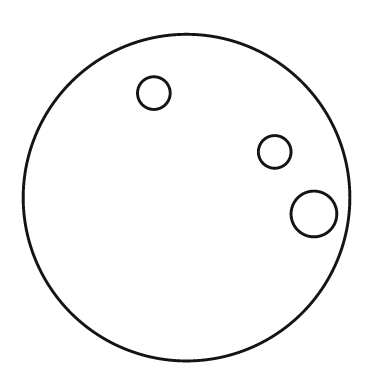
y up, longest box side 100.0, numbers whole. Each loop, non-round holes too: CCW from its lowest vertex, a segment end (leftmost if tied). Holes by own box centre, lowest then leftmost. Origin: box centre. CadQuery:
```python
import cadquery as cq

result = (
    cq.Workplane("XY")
    .moveTo(0.0, 0.0)
    .circle(50.0)
    .moveTo(39.0, -5.0)
    .circle(7.0)
    .moveTo(27.0, 14.0)
    .circle(5.0)
    .moveTo(-10.0, 32.0)
    .circle(5.0)
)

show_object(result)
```